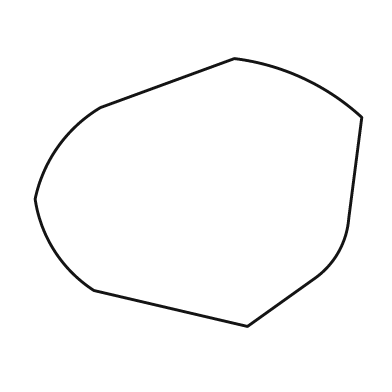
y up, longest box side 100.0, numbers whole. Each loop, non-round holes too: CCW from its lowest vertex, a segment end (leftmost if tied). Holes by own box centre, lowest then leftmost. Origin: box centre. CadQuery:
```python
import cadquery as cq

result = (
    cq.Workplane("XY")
    .moveTo(15.0, -41.0)
    .lineTo(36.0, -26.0)
    .threePointArc((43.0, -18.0), (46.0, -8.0))
    .lineTo(50.0, 23.0)
    .threePointArc((32.0, 35.0), (11.0, 41.0))
    .lineTo(-30.0, 26.0)
    .threePointArc((-43.0, 14.0), (-50.0, -2.0))
    .threePointArc((-44.0, -18.0), (-32.0, -30.0))
    .close()
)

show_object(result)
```